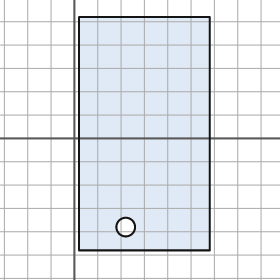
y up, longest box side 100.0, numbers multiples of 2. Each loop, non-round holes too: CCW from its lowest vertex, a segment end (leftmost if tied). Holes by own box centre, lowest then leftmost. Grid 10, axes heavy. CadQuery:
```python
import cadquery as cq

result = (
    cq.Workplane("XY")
    .moveTo(2.0, -48.0)
    .lineTo(58.0, -48.0)
    .lineTo(58.0, 52.0)
    .lineTo(2.0, 52.0)
    .close()
    .moveTo(22.0, -38.0)
    .circle(4.0)
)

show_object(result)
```